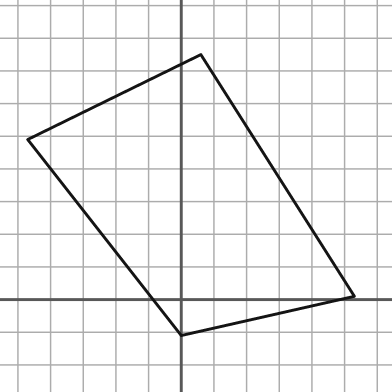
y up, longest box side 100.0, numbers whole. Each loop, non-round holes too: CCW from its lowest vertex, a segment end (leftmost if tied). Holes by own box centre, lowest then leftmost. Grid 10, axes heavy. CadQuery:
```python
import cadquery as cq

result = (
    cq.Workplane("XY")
    .moveTo(0.0, -11.0)
    .lineTo(53.0, 1.0)
    .lineTo(6.0, 75.0)
    .lineTo(-47.0, 49.0)
    .close()
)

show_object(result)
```